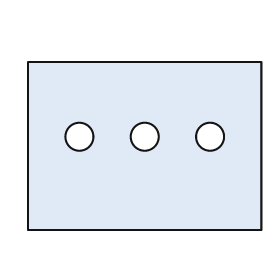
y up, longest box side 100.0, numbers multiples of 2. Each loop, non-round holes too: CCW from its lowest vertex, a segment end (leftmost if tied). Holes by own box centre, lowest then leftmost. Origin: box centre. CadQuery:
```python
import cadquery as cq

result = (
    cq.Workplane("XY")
    .moveTo(-50.0, -36.0)
    .lineTo(50.0, -36.0)
    .lineTo(50.0, 36.0)
    .lineTo(-50.0, 36.0)
    .close()
    .moveTo(-28.0, 4.0)
    .circle(6.0)
    .moveTo(0.0, 4.0)
    .circle(6.0)
    .moveTo(28.0, 4.0)
    .circle(6.0)
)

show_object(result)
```